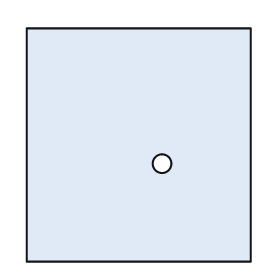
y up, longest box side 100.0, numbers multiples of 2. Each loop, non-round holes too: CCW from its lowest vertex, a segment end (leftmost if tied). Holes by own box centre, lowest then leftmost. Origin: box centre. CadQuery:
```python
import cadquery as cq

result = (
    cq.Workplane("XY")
    .moveTo(-48.0, -50.0)
    .lineTo(48.0, -50.0)
    .lineTo(48.0, 50.0)
    .lineTo(-48.0, 50.0)
    .close()
    .moveTo(10.0, -8.0)
    .circle(4.0)
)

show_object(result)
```